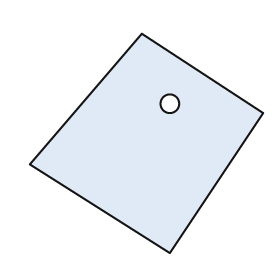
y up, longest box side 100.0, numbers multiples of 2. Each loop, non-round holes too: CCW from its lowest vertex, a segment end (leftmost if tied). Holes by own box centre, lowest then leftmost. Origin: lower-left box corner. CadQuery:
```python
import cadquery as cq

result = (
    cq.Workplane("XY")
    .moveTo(60.0, 0.0)
    .lineTo(100.0, 60.0)
    .lineTo(48.0, 94.0)
    .lineTo(0.0, 38.0)
    .close()
    .moveTo(60.0, 64.0)
    .circle(4.0)
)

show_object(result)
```